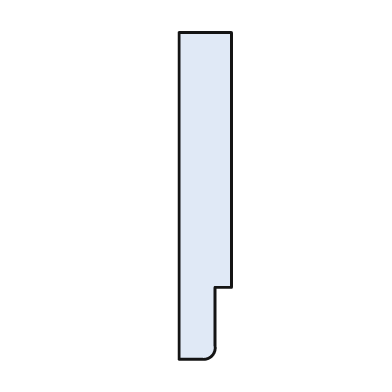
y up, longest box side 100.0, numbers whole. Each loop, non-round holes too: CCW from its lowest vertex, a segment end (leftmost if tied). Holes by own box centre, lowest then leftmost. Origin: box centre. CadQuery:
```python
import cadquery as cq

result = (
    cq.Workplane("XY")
    .moveTo(-8.0, -50.0)
    .lineTo(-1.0, -50.0)
    .threePointArc((2.0, -49.0), (3.0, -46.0))
    .lineTo(3.0, -28.0)
    .lineTo(8.0, -28.0)
    .lineTo(8.0, 50.0)
    .lineTo(-8.0, 50.0)
    .close()
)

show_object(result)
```